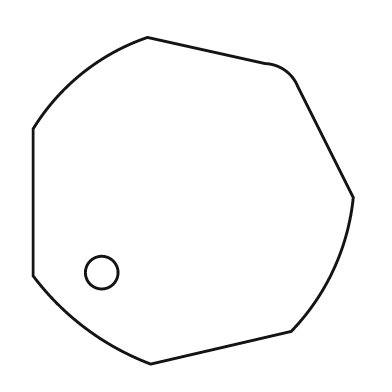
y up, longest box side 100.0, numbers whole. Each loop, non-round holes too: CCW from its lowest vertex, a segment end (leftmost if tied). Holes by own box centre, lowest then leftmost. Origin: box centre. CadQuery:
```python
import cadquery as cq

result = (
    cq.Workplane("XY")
    .moveTo(-13.0, -50.0)
    .lineTo(30.0, -40.0)
    .threePointArc((43.0, -21.0), (49.0, 1.0))
    .lineTo(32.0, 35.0)
    .threePointArc((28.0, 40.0), (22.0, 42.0))
    .lineTo(-14.0, 50.0)
    .threePointArc((-34.0, 39.0), (-49.0, 22.0))
    .lineTo(-49.0, -23.0)
    .threePointArc((-33.0, -39.0), (-13.0, -50.0))
    .close()
    .moveTo(-28.0, -22.0)
    .circle(5.0)
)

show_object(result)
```